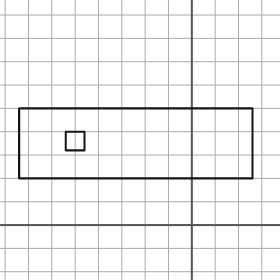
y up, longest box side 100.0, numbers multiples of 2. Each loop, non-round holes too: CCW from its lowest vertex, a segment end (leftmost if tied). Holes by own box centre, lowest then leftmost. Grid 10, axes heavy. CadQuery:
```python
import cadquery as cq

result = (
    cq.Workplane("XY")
    .moveTo(-74.0, 20.0)
    .lineTo(26.0, 20.0)
    .lineTo(26.0, 50.0)
    .lineTo(-74.0, 50.0)
    .close()
    .moveTo(-54.0, 32.0)
    .lineTo(-46.0, 32.0)
    .lineTo(-46.0, 40.0)
    .lineTo(-54.0, 40.0)
    .close()
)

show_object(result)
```